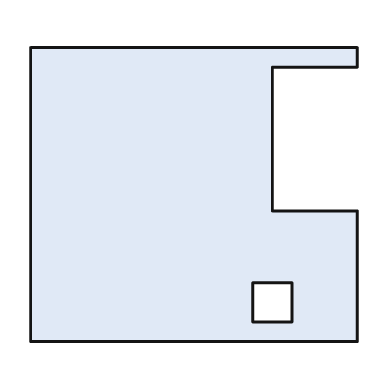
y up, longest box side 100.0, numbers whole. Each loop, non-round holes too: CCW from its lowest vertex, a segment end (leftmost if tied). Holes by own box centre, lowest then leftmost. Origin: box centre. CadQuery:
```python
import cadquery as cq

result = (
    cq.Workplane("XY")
    .moveTo(-50.0, -45.0)
    .lineTo(50.0, -45.0)
    .lineTo(50.0, -5.0)
    .lineTo(24.0, -5.0)
    .lineTo(24.0, 39.0)
    .lineTo(50.0, 39.0)
    .lineTo(50.0, 45.0)
    .lineTo(-50.0, 45.0)
    .close()
    .moveTo(18.0, -39.0)
    .lineTo(30.0, -39.0)
    .lineTo(30.0, -27.0)
    .lineTo(18.0, -27.0)
    .close()
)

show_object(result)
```